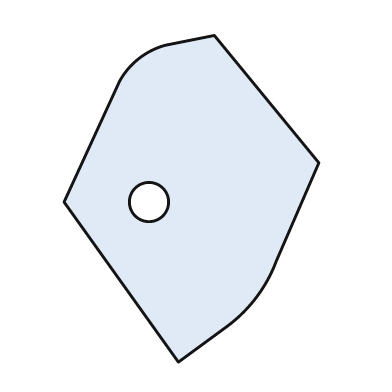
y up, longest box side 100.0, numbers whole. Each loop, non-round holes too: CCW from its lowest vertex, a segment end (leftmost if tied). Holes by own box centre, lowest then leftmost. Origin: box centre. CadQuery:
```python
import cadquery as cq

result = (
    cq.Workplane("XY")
    .moveTo(-4.0, -50.0)
    .lineTo(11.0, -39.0)
    .threePointArc((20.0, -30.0), (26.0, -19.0))
    .lineTo(39.0, 11.0)
    .lineTo(7.0, 50.0)
    .lineTo(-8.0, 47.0)
    .threePointArc((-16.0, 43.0), (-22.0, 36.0))
    .lineTo(-39.0, -1.0)
    .close()
    .moveTo(-13.0, -1.0)
    .circle(6.0)
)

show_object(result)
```